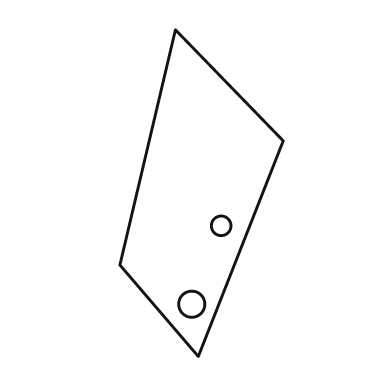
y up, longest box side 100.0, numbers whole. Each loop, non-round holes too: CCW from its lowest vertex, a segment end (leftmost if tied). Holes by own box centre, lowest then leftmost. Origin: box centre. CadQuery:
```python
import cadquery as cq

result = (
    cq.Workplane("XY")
    .moveTo(-1.0, -50.0)
    .lineTo(25.0, 16.0)
    .lineTo(-8.0, 50.0)
    .lineTo(-25.0, -22.0)
    .close()
    .moveTo(-3.0, -34.0)
    .circle(4.0)
    .moveTo(6.0, -10.0)
    .circle(3.0)
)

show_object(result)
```